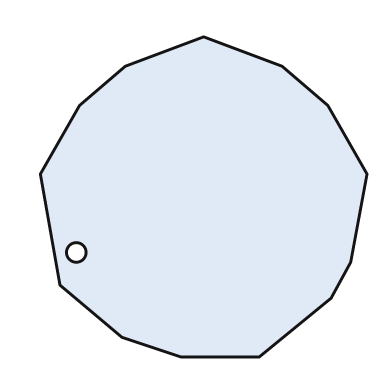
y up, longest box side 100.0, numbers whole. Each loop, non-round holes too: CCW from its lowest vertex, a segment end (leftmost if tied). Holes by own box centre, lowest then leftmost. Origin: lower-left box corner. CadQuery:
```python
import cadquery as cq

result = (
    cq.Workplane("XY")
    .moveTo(43.0, 0.0)
    .lineTo(67.0, 0.0)
    .lineTo(89.0, 18.0)
    .lineTo(95.0, 29.0)
    .lineTo(100.0, 56.0)
    .lineTo(88.0, 77.0)
    .lineTo(74.0, 89.0)
    .lineTo(50.0, 98.0)
    .lineTo(26.0, 89.0)
    .lineTo(12.0, 77.0)
    .lineTo(0.0, 56.0)
    .lineTo(6.0, 22.0)
    .lineTo(25.0, 6.0)
    .close()
    .moveTo(11.0, 32.0)
    .circle(3.0)
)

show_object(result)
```